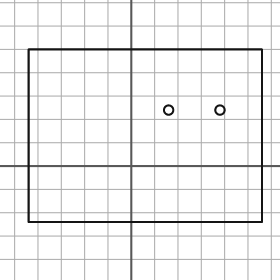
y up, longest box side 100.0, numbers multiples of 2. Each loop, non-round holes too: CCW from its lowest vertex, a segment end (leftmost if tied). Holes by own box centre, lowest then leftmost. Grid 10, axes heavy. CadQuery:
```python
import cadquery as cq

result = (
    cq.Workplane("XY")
    .moveTo(-44.0, -24.0)
    .lineTo(56.0, -24.0)
    .lineTo(56.0, 50.0)
    .lineTo(-44.0, 50.0)
    .close()
    .moveTo(16.0, 24.0)
    .circle(2.0)
    .moveTo(38.0, 24.0)
    .circle(2.0)
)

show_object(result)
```